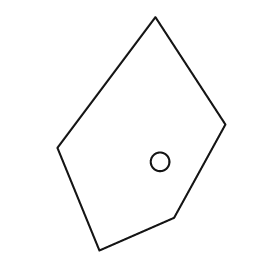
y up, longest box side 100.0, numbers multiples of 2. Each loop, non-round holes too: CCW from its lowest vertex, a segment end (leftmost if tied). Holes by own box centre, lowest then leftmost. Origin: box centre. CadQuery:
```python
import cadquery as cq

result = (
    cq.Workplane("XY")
    .moveTo(-18.0, -50.0)
    .lineTo(14.0, -36.0)
    .lineTo(36.0, 4.0)
    .lineTo(6.0, 50.0)
    .lineTo(-36.0, -6.0)
    .close()
    .moveTo(8.0, -12.0)
    .circle(4.0)
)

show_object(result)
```